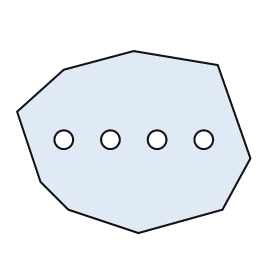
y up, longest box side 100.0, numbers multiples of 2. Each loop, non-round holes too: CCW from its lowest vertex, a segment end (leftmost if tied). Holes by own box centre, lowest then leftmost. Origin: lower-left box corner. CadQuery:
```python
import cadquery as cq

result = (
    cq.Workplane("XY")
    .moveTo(52.0, 0.0)
    .lineTo(88.0, 10.0)
    .lineTo(100.0, 32.0)
    .lineTo(86.0, 72.0)
    .lineTo(50.0, 78.0)
    .lineTo(20.0, 70.0)
    .lineTo(0.0, 52.0)
    .lineTo(10.0, 22.0)
    .lineTo(22.0, 10.0)
    .close()
    .moveTo(20.0, 40.0)
    .circle(4.0)
    .moveTo(40.0, 40.0)
    .circle(4.0)
    .moveTo(60.0, 40.0)
    .circle(4.0)
    .moveTo(80.0, 40.0)
    .circle(4.0)
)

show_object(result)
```